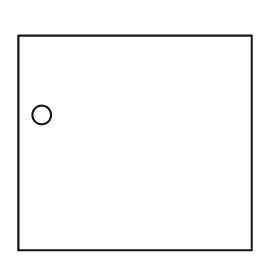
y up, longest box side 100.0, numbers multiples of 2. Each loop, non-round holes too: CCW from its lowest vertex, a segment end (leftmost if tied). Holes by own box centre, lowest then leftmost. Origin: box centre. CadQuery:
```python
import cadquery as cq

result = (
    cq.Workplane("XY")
    .moveTo(-50.0, -46.0)
    .lineTo(50.0, -46.0)
    .lineTo(50.0, 46.0)
    .lineTo(-50.0, 46.0)
    .close()
    .moveTo(-40.0, 12.0)
    .circle(4.0)
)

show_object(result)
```